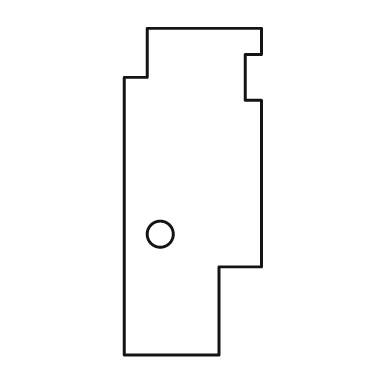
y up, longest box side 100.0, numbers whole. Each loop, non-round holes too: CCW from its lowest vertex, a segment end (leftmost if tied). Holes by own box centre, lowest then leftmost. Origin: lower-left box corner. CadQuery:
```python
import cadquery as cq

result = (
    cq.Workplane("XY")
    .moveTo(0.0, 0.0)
    .lineTo(29.0, 0.0)
    .lineTo(29.0, 27.0)
    .lineTo(42.0, 27.0)
    .lineTo(42.0, 78.0)
    .lineTo(37.0, 78.0)
    .lineTo(37.0, 92.0)
    .lineTo(42.0, 92.0)
    .lineTo(42.0, 100.0)
    .lineTo(7.0, 100.0)
    .lineTo(7.0, 85.0)
    .lineTo(0.0, 85.0)
    .close()
    .moveTo(11.0, 37.0)
    .circle(4.0)
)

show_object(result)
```